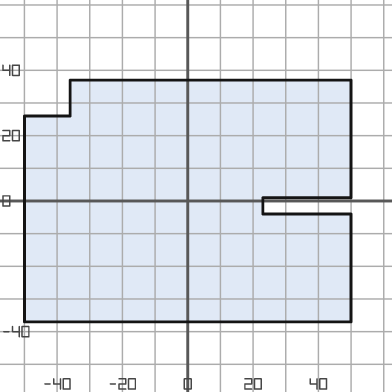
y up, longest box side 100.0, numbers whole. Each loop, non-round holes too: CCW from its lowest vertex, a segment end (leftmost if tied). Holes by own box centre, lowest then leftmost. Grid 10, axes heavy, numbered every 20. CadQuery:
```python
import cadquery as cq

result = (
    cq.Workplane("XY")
    .moveTo(-50.0, -37.0)
    .lineTo(50.0, -37.0)
    .lineTo(50.0, -4.0)
    .lineTo(23.0, -4.0)
    .lineTo(23.0, 1.0)
    .lineTo(50.0, 1.0)
    .lineTo(50.0, 37.0)
    .lineTo(-36.0, 37.0)
    .lineTo(-36.0, 26.0)
    .lineTo(-50.0, 26.0)
    .close()
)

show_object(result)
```